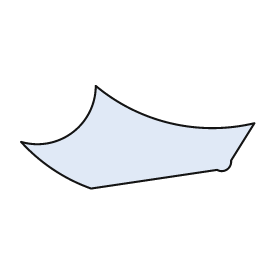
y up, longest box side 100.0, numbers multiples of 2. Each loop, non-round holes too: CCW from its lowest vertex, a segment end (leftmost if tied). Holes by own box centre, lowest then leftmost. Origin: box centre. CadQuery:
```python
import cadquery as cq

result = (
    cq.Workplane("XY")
    .moveTo(-20.0, -22.0)
    .lineTo(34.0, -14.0)
    .threePointArc((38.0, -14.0), (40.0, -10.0))
    .lineTo(50.0, 6.0)
    .threePointArc((14.0, 6.0), (-18.0, 22.0))
    .threePointArc((-28.0, 2.0), (-50.0, -2.0))
    .threePointArc((-36.0, -14.0), (-20.0, -22.0))
    .close()
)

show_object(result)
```